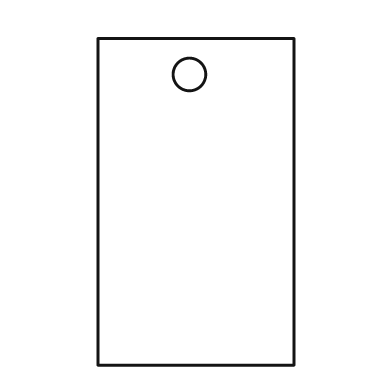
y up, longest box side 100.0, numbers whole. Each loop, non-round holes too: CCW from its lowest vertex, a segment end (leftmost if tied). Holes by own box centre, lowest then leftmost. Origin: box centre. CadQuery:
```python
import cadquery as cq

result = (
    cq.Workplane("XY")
    .moveTo(-30.0, -50.0)
    .lineTo(30.0, -50.0)
    .lineTo(30.0, 50.0)
    .lineTo(-30.0, 50.0)
    .close()
    .moveTo(-2.0, 39.0)
    .circle(5.0)
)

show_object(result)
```